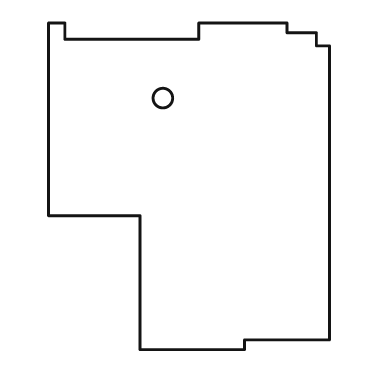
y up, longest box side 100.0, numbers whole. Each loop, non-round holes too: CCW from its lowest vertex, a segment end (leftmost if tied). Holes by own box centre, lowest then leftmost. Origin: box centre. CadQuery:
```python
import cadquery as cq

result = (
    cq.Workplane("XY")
    .moveTo(-15.0, -50.0)
    .lineTo(17.0, -50.0)
    .lineTo(17.0, -47.0)
    .lineTo(43.0, -47.0)
    .lineTo(43.0, 43.0)
    .lineTo(39.0, 43.0)
    .lineTo(39.0, 47.0)
    .lineTo(30.0, 47.0)
    .lineTo(30.0, 50.0)
    .lineTo(3.0, 50.0)
    .lineTo(3.0, 45.0)
    .lineTo(-38.0, 45.0)
    .lineTo(-38.0, 50.0)
    .lineTo(-43.0, 50.0)
    .lineTo(-43.0, -9.0)
    .lineTo(-15.0, -9.0)
    .close()
    .moveTo(-8.0, 27.0)
    .circle(3.0)
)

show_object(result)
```